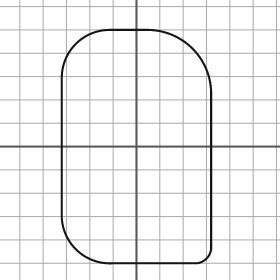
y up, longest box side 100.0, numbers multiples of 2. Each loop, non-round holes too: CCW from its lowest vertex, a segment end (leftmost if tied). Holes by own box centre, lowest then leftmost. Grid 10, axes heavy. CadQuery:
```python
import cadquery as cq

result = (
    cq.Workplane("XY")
    .moveTo(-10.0, -50.0)
    .lineTo(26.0, -50.0)
    .threePointArc((30.0, -48.0), (32.0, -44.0))
    .lineTo(32.0, 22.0)
    .threePointArc((24.0, 42.0), (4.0, 50.0))
    .lineTo(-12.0, 50.0)
    .threePointArc((-26.0, 44.0), (-32.0, 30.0))
    .lineTo(-32.0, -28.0)
    .threePointArc((-26.0, -44.0), (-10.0, -50.0))
    .close()
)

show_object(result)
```